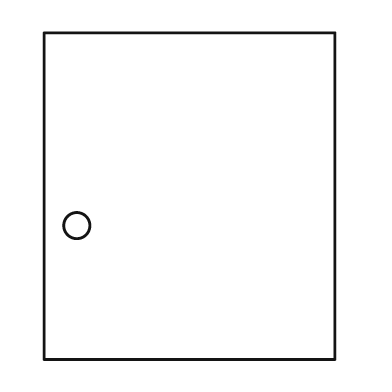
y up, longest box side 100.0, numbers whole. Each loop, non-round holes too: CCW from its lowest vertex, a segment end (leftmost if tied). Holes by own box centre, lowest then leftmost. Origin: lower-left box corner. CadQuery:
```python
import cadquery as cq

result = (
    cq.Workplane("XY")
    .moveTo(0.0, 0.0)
    .lineTo(89.0, 0.0)
    .lineTo(89.0, 100.0)
    .lineTo(0.0, 100.0)
    .close()
    .moveTo(10.0, 41.0)
    .circle(4.0)
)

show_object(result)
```